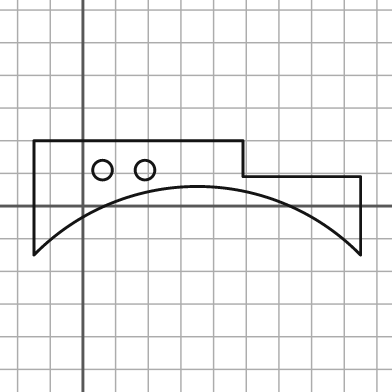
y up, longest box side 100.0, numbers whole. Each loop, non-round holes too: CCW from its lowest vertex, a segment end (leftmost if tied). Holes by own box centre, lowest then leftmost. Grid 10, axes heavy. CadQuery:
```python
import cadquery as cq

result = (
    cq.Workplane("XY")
    .moveTo(-15.0, -15.0)
    .threePointArc((35.0, 6.0), (85.0, -15.0))
    .lineTo(85.0, 9.0)
    .lineTo(49.0, 9.0)
    .lineTo(49.0, 20.0)
    .lineTo(-15.0, 20.0)
    .close()
    .moveTo(6.0, 11.0)
    .circle(3.0)
    .moveTo(19.0, 11.0)
    .circle(3.0)
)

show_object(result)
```